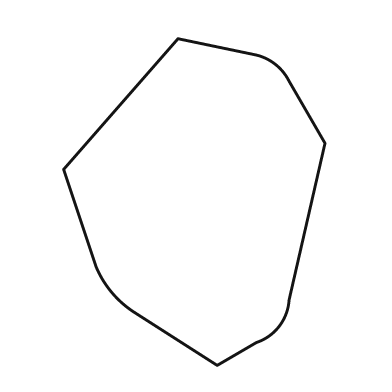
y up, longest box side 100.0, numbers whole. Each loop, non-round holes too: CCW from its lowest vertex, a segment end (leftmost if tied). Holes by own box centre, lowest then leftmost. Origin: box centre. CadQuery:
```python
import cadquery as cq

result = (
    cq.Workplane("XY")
    .moveTo(7.0, -50.0)
    .lineTo(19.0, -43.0)
    .threePointArc((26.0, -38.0), (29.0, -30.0))
    .lineTo(40.0, 18.0)
    .lineTo(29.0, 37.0)
    .threePointArc((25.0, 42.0), (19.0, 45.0))
    .lineTo(-5.0, 50.0)
    .lineTo(-40.0, 10.0)
    .lineTo(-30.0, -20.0)
    .threePointArc((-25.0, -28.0), (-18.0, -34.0))
    .close()
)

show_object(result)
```